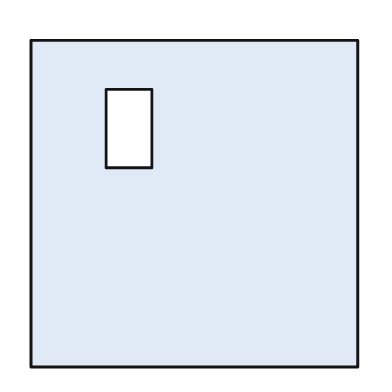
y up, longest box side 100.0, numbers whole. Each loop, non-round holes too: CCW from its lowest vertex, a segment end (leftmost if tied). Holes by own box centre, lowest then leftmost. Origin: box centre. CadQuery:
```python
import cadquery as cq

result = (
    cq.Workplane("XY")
    .moveTo(-50.0, -50.0)
    .lineTo(50.0, -50.0)
    .lineTo(50.0, 50.0)
    .lineTo(-50.0, 50.0)
    .close()
    .moveTo(-27.0, 11.0)
    .lineTo(-13.0, 11.0)
    .lineTo(-13.0, 35.0)
    .lineTo(-27.0, 35.0)
    .close()
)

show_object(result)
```